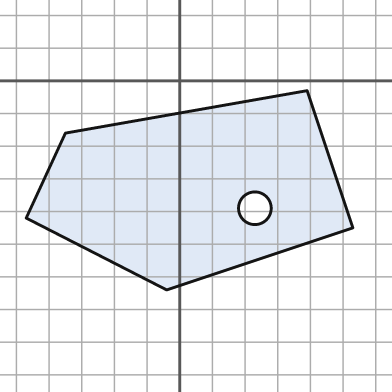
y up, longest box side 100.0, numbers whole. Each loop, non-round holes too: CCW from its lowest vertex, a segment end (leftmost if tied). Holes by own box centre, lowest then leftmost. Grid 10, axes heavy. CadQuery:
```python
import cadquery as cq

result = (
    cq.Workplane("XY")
    .moveTo(-4.0, -64.0)
    .lineTo(53.0, -45.0)
    .lineTo(39.0, -3.0)
    .lineTo(-35.0, -16.0)
    .lineTo(-47.0, -42.0)
    .close()
    .moveTo(23.0, -39.0)
    .circle(5.0)
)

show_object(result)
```